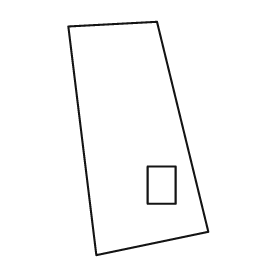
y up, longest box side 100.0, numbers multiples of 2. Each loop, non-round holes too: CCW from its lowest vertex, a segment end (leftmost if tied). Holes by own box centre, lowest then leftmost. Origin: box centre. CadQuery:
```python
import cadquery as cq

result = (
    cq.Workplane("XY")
    .moveTo(-18.0, -50.0)
    .lineTo(30.0, -40.0)
    .lineTo(8.0, 50.0)
    .lineTo(-30.0, 48.0)
    .close()
    .moveTo(4.0, -28.0)
    .lineTo(16.0, -28.0)
    .lineTo(16.0, -12.0)
    .lineTo(4.0, -12.0)
    .close()
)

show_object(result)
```